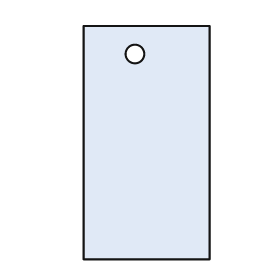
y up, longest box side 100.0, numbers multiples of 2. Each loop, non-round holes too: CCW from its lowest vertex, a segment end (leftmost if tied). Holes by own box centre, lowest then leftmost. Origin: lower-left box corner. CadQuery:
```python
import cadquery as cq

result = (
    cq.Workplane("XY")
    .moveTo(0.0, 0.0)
    .lineTo(54.0, 0.0)
    .lineTo(54.0, 100.0)
    .lineTo(0.0, 100.0)
    .close()
    .moveTo(22.0, 88.0)
    .circle(4.0)
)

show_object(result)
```